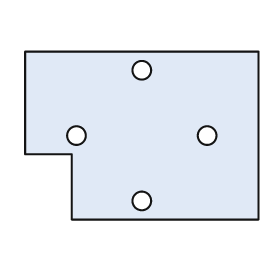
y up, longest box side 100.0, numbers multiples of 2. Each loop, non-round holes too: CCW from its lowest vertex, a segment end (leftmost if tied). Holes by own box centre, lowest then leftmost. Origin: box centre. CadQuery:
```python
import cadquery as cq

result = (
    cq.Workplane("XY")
    .moveTo(-30.0, -36.0)
    .lineTo(50.0, -36.0)
    .lineTo(50.0, 36.0)
    .lineTo(-50.0, 36.0)
    .lineTo(-50.0, -8.0)
    .lineTo(-30.0, -8.0)
    .close()
    .moveTo(0.0, -28.0)
    .circle(4.0)
    .moveTo(-28.0, 0.0)
    .circle(4.0)
    .moveTo(28.0, 0.0)
    .circle(4.0)
    .moveTo(0.0, 28.0)
    .circle(4.0)
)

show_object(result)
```